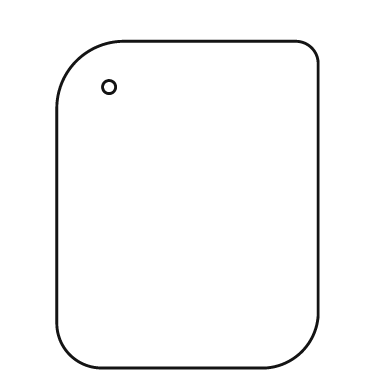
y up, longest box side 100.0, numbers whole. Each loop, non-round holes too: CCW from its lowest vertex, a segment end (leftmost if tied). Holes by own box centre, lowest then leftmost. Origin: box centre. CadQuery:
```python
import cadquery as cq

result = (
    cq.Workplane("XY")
    .moveTo(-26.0, -50.0)
    .lineTo(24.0, -50.0)
    .threePointArc((35.0, -45.0), (40.0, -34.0))
    .lineTo(40.0, 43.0)
    .threePointArc((38.0, 48.0), (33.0, 50.0))
    .lineTo(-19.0, 50.0)
    .threePointArc((-34.0, 44.0), (-40.0, 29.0))
    .lineTo(-40.0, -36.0)
    .threePointArc((-36.0, -46.0), (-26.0, -50.0))
    .close()
    .moveTo(-24.0, 36.0)
    .circle(2.0)
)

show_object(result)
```